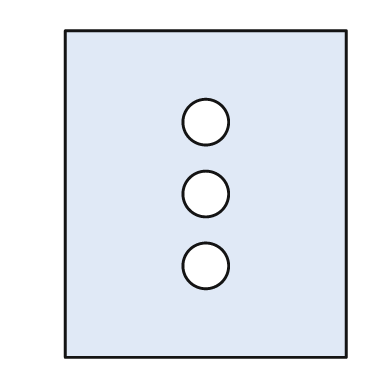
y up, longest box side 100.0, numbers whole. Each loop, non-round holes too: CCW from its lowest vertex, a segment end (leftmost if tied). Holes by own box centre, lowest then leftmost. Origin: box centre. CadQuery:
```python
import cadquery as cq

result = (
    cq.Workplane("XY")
    .moveTo(-43.0, -50.0)
    .lineTo(43.0, -50.0)
    .lineTo(43.0, 50.0)
    .lineTo(-43.0, 50.0)
    .close()
    .moveTo(0.0, -22.0)
    .circle(7.0)
    .moveTo(0.0, 0.0)
    .circle(7.0)
    .moveTo(0.0, 22.0)
    .circle(7.0)
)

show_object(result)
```